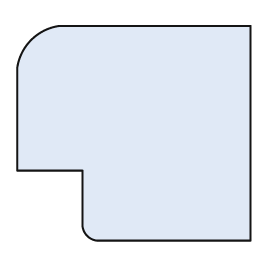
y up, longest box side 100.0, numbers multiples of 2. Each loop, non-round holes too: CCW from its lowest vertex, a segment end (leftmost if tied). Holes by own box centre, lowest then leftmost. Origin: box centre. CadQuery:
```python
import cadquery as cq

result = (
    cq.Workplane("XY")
    .moveTo(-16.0, -46.0)
    .lineTo(50.0, -46.0)
    .lineTo(50.0, 46.0)
    .lineTo(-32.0, 46.0)
    .threePointArc((-44.0, 40.0), (-50.0, 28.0))
    .lineTo(-50.0, -16.0)
    .lineTo(-22.0, -16.0)
    .lineTo(-22.0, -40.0)
    .threePointArc((-20.0, -44.0), (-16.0, -46.0))
    .close()
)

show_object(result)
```